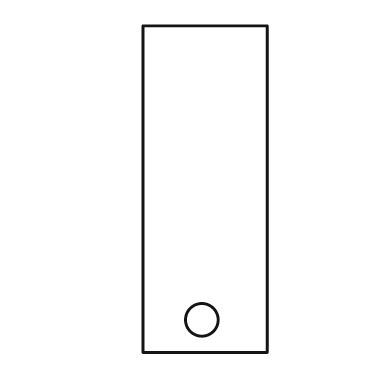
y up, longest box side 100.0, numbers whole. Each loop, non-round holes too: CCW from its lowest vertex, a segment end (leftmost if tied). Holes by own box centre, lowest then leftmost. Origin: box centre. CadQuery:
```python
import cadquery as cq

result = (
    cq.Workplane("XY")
    .moveTo(-19.0, -50.0)
    .lineTo(19.0, -50.0)
    .lineTo(19.0, 50.0)
    .lineTo(-19.0, 50.0)
    .close()
    .moveTo(-1.0, -40.0)
    .circle(5.0)
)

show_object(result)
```